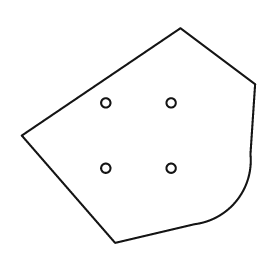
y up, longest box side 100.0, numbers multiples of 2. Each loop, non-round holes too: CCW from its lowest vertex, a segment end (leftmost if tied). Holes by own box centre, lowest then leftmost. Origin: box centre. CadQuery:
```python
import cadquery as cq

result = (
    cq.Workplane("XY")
    .moveTo(-10.0, -46.0)
    .lineTo(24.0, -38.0)
    .threePointArc((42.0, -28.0), (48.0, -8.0))
    .lineTo(50.0, 22.0)
    .lineTo(18.0, 46.0)
    .lineTo(-50.0, 0.0)
    .close()
    .moveTo(-14.0, -14.0)
    .circle(2.0)
    .moveTo(14.0, -14.0)
    .circle(2.0)
    .moveTo(-14.0, 14.0)
    .circle(2.0)
    .moveTo(14.0, 14.0)
    .circle(2.0)
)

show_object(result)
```